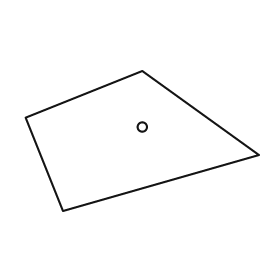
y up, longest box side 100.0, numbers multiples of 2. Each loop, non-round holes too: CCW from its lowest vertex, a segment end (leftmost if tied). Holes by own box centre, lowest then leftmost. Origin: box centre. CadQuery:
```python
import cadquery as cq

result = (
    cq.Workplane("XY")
    .moveTo(-34.0, -30.0)
    .lineTo(50.0, -6.0)
    .lineTo(0.0, 30.0)
    .lineTo(-50.0, 10.0)
    .close()
    .moveTo(0.0, 6.0)
    .circle(2.0)
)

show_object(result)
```